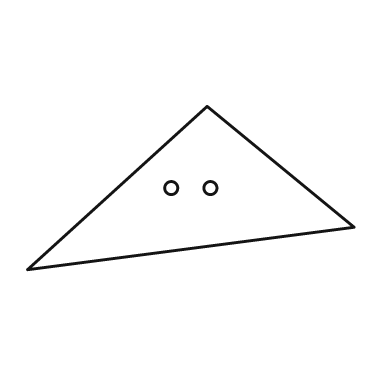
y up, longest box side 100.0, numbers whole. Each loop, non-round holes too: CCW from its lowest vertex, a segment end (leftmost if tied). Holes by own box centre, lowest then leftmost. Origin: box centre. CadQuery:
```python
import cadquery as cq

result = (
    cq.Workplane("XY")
    .moveTo(-50.0, -25.0)
    .lineTo(50.0, -12.0)
    .lineTo(5.0, 25.0)
    .close()
    .moveTo(-6.0, 0.0)
    .circle(2.0)
    .moveTo(6.0, 0.0)
    .circle(2.0)
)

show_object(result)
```